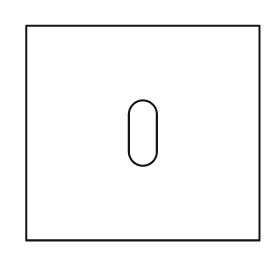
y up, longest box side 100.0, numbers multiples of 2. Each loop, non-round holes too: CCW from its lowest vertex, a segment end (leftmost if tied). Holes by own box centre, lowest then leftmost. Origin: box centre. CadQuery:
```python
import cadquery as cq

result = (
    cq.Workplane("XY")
    .moveTo(-50.0, -46.0)
    .lineTo(50.0, -46.0)
    .lineTo(50.0, 46.0)
    .lineTo(-50.0, 46.0)
    .close()
    .moveTo(-6.0, -8.0)
    .threePointArc((0.0, -14.0), (6.0, -8.0))
    .lineTo(6.0, 8.0)
    .threePointArc((0.0, 14.0), (-6.0, 8.0))
    .close()
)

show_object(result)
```